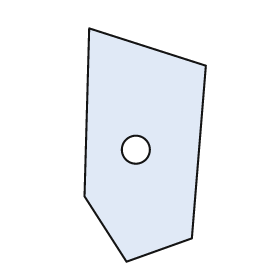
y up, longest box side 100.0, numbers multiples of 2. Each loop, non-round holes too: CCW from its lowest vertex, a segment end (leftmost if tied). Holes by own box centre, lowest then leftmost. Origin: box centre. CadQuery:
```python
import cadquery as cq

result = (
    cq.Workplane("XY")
    .moveTo(-8.0, -50.0)
    .lineTo(20.0, -40.0)
    .lineTo(26.0, 34.0)
    .lineTo(-24.0, 50.0)
    .lineTo(-26.0, -22.0)
    .close()
    .moveTo(-4.0, -2.0)
    .circle(6.0)
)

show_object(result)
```